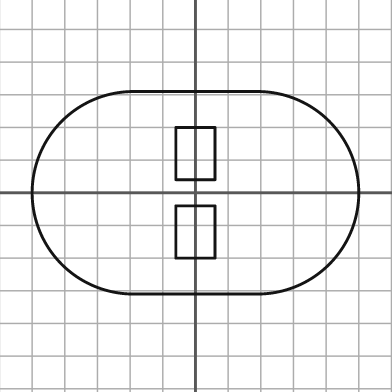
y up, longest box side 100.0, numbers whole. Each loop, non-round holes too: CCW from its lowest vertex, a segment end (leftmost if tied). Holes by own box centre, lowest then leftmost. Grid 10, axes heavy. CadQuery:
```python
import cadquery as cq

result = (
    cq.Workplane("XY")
    .moveTo(-19.0, -31.0)
    .lineTo(19.0, -31.0)
    .threePointArc((50.0, 0.0), (19.0, 31.0))
    .lineTo(-19.0, 31.0)
    .threePointArc((-50.0, 0.0), (-19.0, -31.0))
    .close()
    .moveTo(-6.0, -20.0)
    .lineTo(6.0, -20.0)
    .lineTo(6.0, -4.0)
    .lineTo(-6.0, -4.0)
    .close()
    .moveTo(-6.0, 4.0)
    .lineTo(6.0, 4.0)
    .lineTo(6.0, 20.0)
    .lineTo(-6.0, 20.0)
    .close()
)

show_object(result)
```